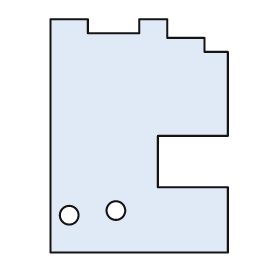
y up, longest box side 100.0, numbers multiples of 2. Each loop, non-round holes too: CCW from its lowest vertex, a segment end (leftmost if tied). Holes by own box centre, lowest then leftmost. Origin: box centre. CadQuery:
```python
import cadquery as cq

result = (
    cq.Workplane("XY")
    .moveTo(-38.0, -50.0)
    .lineTo(38.0, -50.0)
    .lineTo(38.0, -22.0)
    .lineTo(8.0, -22.0)
    .lineTo(8.0, 0.0)
    .lineTo(38.0, 0.0)
    .lineTo(38.0, 36.0)
    .lineTo(28.0, 36.0)
    .lineTo(28.0, 42.0)
    .lineTo(12.0, 42.0)
    .lineTo(12.0, 50.0)
    .lineTo(0.0, 50.0)
    .lineTo(0.0, 44.0)
    .lineTo(-22.0, 44.0)
    .lineTo(-22.0, 50.0)
    .lineTo(-38.0, 50.0)
    .close()
    .moveTo(-30.0, -34.0)
    .circle(4.0)
    .moveTo(-10.0, -32.0)
    .circle(4.0)
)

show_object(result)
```